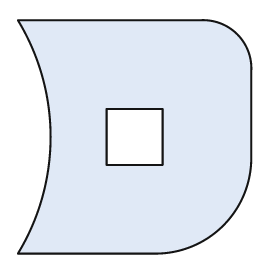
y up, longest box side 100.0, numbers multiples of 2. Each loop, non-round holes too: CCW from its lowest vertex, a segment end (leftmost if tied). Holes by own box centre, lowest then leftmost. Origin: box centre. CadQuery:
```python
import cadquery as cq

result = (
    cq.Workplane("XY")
    .moveTo(-50.0, -50.0)
    .lineTo(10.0, -50.0)
    .threePointArc((38.0, -38.0), (50.0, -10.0))
    .lineTo(50.0, 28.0)
    .threePointArc((44.0, 44.0), (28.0, 50.0))
    .lineTo(-50.0, 50.0)
    .threePointArc((-36.0, 0.0), (-50.0, -50.0))
    .close()
    .moveTo(-12.0, -12.0)
    .lineTo(12.0, -12.0)
    .lineTo(12.0, 12.0)
    .lineTo(-12.0, 12.0)
    .close()
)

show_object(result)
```